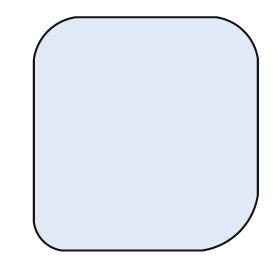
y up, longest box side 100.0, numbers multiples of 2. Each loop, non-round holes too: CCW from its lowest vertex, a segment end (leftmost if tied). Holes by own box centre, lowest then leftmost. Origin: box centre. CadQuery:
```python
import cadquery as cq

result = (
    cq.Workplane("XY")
    .moveTo(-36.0, -50.0)
    .lineTo(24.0, -50.0)
    .threePointArc((40.0, -42.0), (48.0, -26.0))
    .lineTo(48.0, 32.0)
    .threePointArc((42.0, 44.0), (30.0, 50.0))
    .lineTo(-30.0, 50.0)
    .threePointArc((-42.0, 44.0), (-48.0, 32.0))
    .lineTo(-48.0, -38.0)
    .threePointArc((-44.0, -46.0), (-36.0, -50.0))
    .close()
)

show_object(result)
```